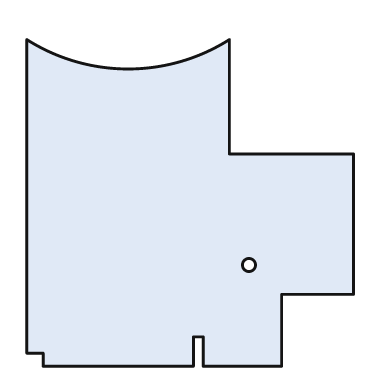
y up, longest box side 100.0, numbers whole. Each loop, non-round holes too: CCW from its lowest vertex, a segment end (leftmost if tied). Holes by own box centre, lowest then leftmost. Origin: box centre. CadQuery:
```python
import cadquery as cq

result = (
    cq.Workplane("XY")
    .moveTo(-45.0, -50.0)
    .lineTo(1.0, -50.0)
    .lineTo(1.0, -41.0)
    .lineTo(4.0, -41.0)
    .lineTo(4.0, -50.0)
    .lineTo(28.0, -50.0)
    .lineTo(28.0, -28.0)
    .lineTo(50.0, -28.0)
    .lineTo(50.0, 15.0)
    .lineTo(12.0, 15.0)
    .lineTo(12.0, 50.0)
    .threePointArc((-19.0, 41.0), (-50.0, 50.0))
    .lineTo(-50.0, -46.0)
    .lineTo(-45.0, -46.0)
    .close()
    .moveTo(18.0, -19.0)
    .circle(2.0)
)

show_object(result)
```